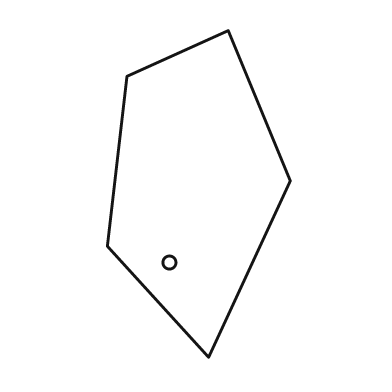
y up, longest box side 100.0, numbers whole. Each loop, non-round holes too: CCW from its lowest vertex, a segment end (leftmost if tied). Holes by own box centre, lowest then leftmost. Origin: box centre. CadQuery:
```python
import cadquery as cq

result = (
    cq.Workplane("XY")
    .moveTo(3.0, -50.0)
    .lineTo(28.0, 4.0)
    .lineTo(9.0, 50.0)
    .lineTo(-22.0, 36.0)
    .lineTo(-28.0, -16.0)
    .close()
    .moveTo(-9.0, -21.0)
    .circle(2.0)
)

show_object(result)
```